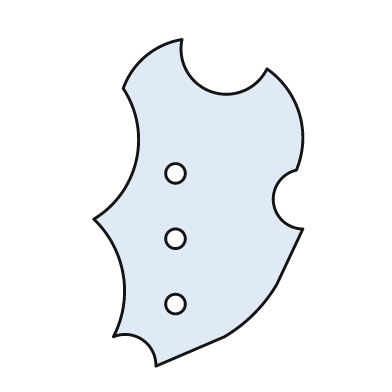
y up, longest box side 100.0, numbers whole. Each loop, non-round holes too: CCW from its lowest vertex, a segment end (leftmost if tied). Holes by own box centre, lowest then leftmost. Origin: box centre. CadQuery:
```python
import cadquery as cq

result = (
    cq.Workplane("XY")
    .moveTo(-13.0, -50.0)
    .lineTo(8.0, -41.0)
    .threePointArc((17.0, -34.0), (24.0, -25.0))
    .lineTo(32.0, -8.0)
    .threePointArc((23.0, 0.0), (30.0, 10.0))
    .threePointArc((31.0, 27.0), (21.0, 41.0))
    .threePointArc((4.0, 34.0), (-5.0, 50.0))
    .threePointArc((-16.0, 45.0), (-23.0, 35.0))
    .threePointArc((-19.0, 13.0), (-32.0, -5.0))
    .threePointArc((-23.0, -22.0), (-26.0, -41.0))
    .threePointArc((-17.0, -42.0), (-13.0, -50.0))
    .close()
    .moveTo(-7.0, -31.0)
    .circle(3.0)
    .moveTo(-7.0, -11.0)
    .circle(3.0)
    .moveTo(-7.0, 9.0)
    .circle(3.0)
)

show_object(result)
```